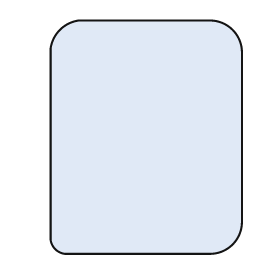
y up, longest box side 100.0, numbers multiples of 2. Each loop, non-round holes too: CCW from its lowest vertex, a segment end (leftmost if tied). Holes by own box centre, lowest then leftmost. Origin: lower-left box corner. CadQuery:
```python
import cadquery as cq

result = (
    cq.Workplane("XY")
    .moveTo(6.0, 0.0)
    .lineTo(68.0, 0.0)
    .threePointArc((78.0, 4.0), (82.0, 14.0))
    .lineTo(82.0, 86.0)
    .threePointArc((78.0, 96.0), (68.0, 100.0))
    .lineTo(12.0, 100.0)
    .threePointArc((4.0, 96.0), (0.0, 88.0))
    .lineTo(0.0, 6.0)
    .threePointArc((2.0, 2.0), (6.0, 0.0))
    .close()
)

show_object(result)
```